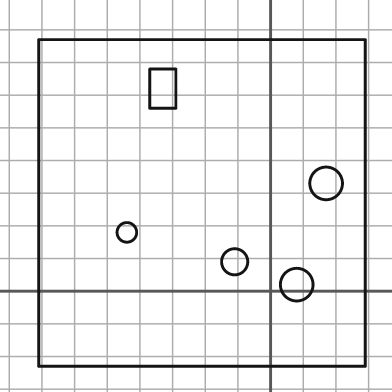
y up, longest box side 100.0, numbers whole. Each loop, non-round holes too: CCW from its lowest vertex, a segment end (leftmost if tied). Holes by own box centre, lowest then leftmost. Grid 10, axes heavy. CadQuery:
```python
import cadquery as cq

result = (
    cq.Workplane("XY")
    .moveTo(-71.0, -23.0)
    .lineTo(29.0, -23.0)
    .lineTo(29.0, 77.0)
    .lineTo(-71.0, 77.0)
    .close()
    .moveTo(8.0, 2.0)
    .circle(5.0)
    .moveTo(-11.0, 9.0)
    .circle(4.0)
    .moveTo(-44.0, 18.0)
    .circle(3.0)
    .moveTo(17.0, 33.0)
    .circle(5.0)
    .moveTo(-37.0, 56.0)
    .lineTo(-29.0, 56.0)
    .lineTo(-29.0, 68.0)
    .lineTo(-37.0, 68.0)
    .close()
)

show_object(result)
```